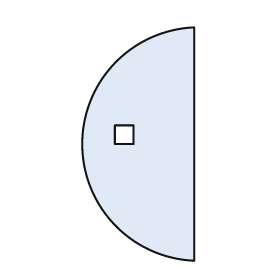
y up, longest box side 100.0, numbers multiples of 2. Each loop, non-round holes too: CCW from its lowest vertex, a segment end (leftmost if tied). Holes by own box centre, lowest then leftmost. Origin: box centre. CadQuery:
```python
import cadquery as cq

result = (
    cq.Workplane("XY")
    .moveTo(24.0, -50.0)
    .lineTo(24.0, 50.0)
    .threePointArc((-24.0, 0.0), (24.0, -50.0))
    .close()
    .moveTo(-10.0, 0.0)
    .lineTo(-2.0, 0.0)
    .lineTo(-2.0, 8.0)
    .lineTo(-10.0, 8.0)
    .close()
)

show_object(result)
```